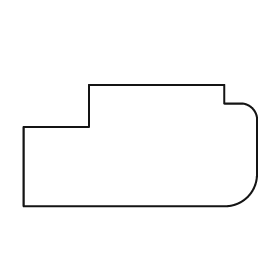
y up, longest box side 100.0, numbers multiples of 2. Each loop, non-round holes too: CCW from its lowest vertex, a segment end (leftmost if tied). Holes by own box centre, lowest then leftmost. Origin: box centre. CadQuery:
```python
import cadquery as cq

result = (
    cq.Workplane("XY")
    .moveTo(-50.0, -26.0)
    .lineTo(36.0, -26.0)
    .threePointArc((46.0, -22.0), (50.0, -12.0))
    .lineTo(50.0, 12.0)
    .threePointArc((48.0, 16.0), (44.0, 18.0))
    .lineTo(36.0, 18.0)
    .lineTo(36.0, 26.0)
    .lineTo(-22.0, 26.0)
    .lineTo(-22.0, 8.0)
    .lineTo(-50.0, 8.0)
    .close()
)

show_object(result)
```